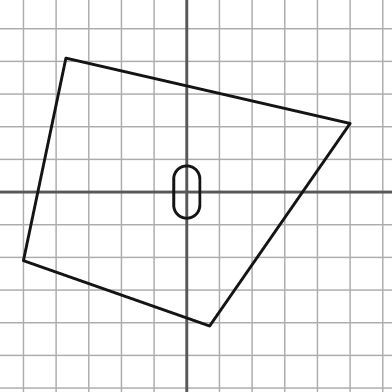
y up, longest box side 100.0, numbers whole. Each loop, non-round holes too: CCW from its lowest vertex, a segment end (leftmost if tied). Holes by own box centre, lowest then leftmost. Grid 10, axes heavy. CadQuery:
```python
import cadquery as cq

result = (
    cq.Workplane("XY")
    .moveTo(7.0, -41.0)
    .lineTo(50.0, 21.0)
    .lineTo(-37.0, 41.0)
    .lineTo(-50.0, -21.0)
    .close()
    .moveTo(-4.0, -4.0)
    .threePointArc((0.0, -8.0), (4.0, -4.0))
    .lineTo(4.0, 4.0)
    .threePointArc((0.0, 8.0), (-4.0, 4.0))
    .close()
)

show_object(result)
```